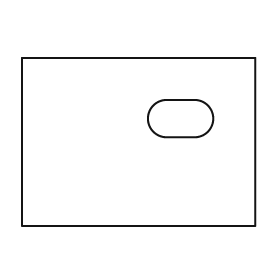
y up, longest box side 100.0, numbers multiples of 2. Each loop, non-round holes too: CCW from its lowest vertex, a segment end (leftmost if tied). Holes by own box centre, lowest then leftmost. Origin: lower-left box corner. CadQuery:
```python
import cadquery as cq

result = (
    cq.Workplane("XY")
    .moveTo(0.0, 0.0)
    .lineTo(100.0, 0.0)
    .lineTo(100.0, 72.0)
    .lineTo(0.0, 72.0)
    .close()
    .moveTo(62.0, 38.0)
    .lineTo(74.0, 38.0)
    .threePointArc((82.0, 46.0), (74.0, 54.0))
    .lineTo(62.0, 54.0)
    .threePointArc((54.0, 46.0), (62.0, 38.0))
    .close()
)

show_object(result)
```